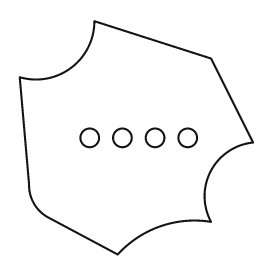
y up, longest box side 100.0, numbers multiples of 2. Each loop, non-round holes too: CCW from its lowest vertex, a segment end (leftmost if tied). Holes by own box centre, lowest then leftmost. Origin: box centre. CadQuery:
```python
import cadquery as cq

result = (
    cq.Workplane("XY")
    .moveTo(-8.0, -50.0)
    .threePointArc((10.0, -38.0), (32.0, -36.0))
    .threePointArc((32.0, -14.0), (50.0, -2.0))
    .lineTo(32.0, 34.0)
    .lineTo(-18.0, 50.0)
    .threePointArc((-28.0, 30.0), (-50.0, 26.0))
    .lineTo(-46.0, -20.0)
    .threePointArc((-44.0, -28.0), (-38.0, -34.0))
    .close()
    .moveTo(-20.0, 0.0)
    .circle(4.0)
    .moveTo(-6.0, 0.0)
    .circle(4.0)
    .moveTo(8.0, 0.0)
    .circle(4.0)
    .moveTo(22.0, 0.0)
    .circle(4.0)
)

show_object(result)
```